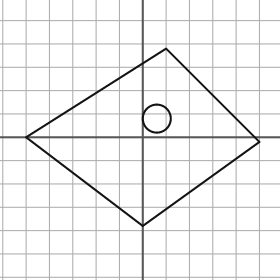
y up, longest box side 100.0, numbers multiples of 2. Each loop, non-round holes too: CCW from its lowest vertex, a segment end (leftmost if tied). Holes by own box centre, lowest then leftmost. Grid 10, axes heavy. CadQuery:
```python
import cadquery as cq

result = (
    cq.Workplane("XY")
    .moveTo(0.0, -38.0)
    .lineTo(50.0, -2.0)
    .lineTo(10.0, 38.0)
    .lineTo(-50.0, 0.0)
    .close()
    .moveTo(6.0, 8.0)
    .circle(6.0)
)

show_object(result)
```